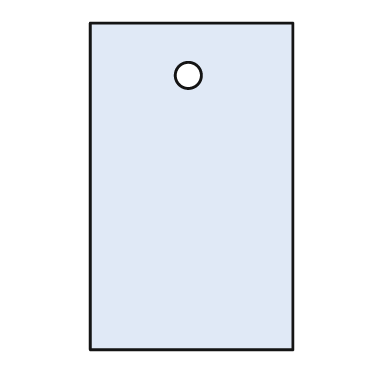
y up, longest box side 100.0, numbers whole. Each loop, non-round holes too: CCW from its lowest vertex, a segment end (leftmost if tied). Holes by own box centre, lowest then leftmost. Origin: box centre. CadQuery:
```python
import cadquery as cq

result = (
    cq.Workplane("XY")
    .moveTo(-31.0, -50.0)
    .lineTo(31.0, -50.0)
    .lineTo(31.0, 50.0)
    .lineTo(-31.0, 50.0)
    .close()
    .moveTo(-1.0, 34.0)
    .circle(4.0)
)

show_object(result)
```